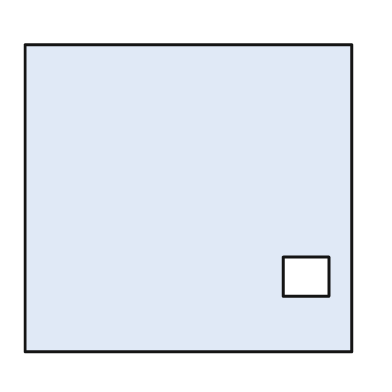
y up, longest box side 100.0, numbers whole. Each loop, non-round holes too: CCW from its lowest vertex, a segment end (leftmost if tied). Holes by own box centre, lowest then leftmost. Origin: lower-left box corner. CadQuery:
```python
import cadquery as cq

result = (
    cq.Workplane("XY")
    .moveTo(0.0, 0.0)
    .lineTo(100.0, 0.0)
    .lineTo(100.0, 94.0)
    .lineTo(0.0, 94.0)
    .close()
    .moveTo(79.0, 17.0)
    .lineTo(93.0, 17.0)
    .lineTo(93.0, 29.0)
    .lineTo(79.0, 29.0)
    .close()
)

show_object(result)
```